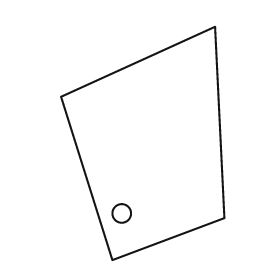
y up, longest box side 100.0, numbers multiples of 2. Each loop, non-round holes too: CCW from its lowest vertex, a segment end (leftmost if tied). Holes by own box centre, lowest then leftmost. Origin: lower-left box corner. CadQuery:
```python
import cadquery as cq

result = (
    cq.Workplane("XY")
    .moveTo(22.0, 0.0)
    .lineTo(70.0, 18.0)
    .lineTo(66.0, 100.0)
    .lineTo(0.0, 70.0)
    .close()
    .moveTo(26.0, 20.0)
    .circle(4.0)
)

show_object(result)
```